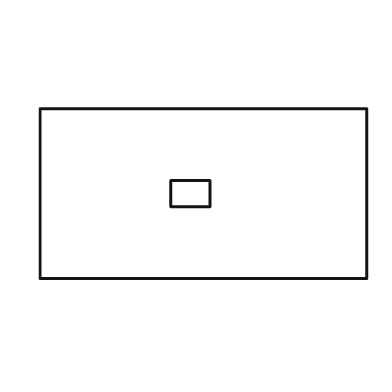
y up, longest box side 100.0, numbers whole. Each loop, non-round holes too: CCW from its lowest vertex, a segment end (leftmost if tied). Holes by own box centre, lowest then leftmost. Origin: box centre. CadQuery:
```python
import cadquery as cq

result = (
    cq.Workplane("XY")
    .moveTo(-50.0, -26.0)
    .lineTo(50.0, -26.0)
    .lineTo(50.0, 26.0)
    .lineTo(-50.0, 26.0)
    .close()
    .moveTo(-10.0, -4.0)
    .lineTo(2.0, -4.0)
    .lineTo(2.0, 4.0)
    .lineTo(-10.0, 4.0)
    .close()
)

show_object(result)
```